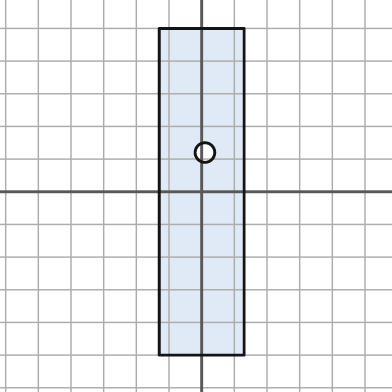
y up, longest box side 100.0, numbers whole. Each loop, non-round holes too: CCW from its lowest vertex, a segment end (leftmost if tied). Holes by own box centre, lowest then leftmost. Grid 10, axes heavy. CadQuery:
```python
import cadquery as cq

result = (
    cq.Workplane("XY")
    .moveTo(-13.0, -50.0)
    .lineTo(13.0, -50.0)
    .lineTo(13.0, 50.0)
    .lineTo(-13.0, 50.0)
    .close()
    .moveTo(1.0, 12.0)
    .circle(3.0)
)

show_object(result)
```